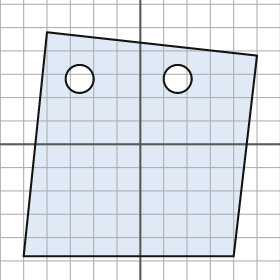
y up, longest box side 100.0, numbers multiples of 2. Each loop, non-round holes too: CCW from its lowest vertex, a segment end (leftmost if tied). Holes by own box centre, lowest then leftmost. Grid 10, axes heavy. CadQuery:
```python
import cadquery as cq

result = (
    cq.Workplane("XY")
    .moveTo(-50.0, -48.0)
    .lineTo(40.0, -48.0)
    .lineTo(50.0, 38.0)
    .lineTo(-40.0, 48.0)
    .close()
    .moveTo(-26.0, 28.0)
    .circle(6.0)
    .moveTo(16.0, 28.0)
    .circle(6.0)
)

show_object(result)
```